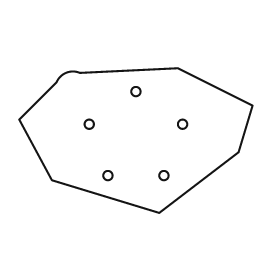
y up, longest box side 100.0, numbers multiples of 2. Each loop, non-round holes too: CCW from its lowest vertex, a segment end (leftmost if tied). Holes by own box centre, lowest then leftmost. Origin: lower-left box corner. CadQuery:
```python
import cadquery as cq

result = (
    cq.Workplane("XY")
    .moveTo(60.0, 0.0)
    .lineTo(94.0, 26.0)
    .lineTo(100.0, 46.0)
    .lineTo(68.0, 62.0)
    .lineTo(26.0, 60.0)
    .threePointArc((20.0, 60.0), (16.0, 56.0))
    .lineTo(0.0, 40.0)
    .lineTo(14.0, 14.0)
    .close()
    .moveTo(38.0, 16.0)
    .circle(2.0)
    .moveTo(62.0, 16.0)
    .circle(2.0)
    .moveTo(30.0, 38.0)
    .circle(2.0)
    .moveTo(70.0, 38.0)
    .circle(2.0)
    .moveTo(50.0, 52.0)
    .circle(2.0)
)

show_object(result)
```